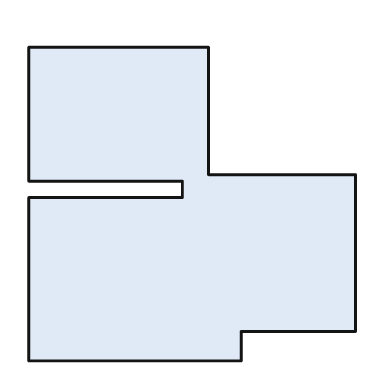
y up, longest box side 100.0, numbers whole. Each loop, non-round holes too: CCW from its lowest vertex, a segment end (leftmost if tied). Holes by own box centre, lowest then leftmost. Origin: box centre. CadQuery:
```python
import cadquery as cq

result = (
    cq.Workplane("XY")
    .moveTo(-50.0, -48.0)
    .lineTo(15.0, -48.0)
    .lineTo(15.0, -39.0)
    .lineTo(50.0, -39.0)
    .lineTo(50.0, 9.0)
    .lineTo(5.0, 9.0)
    .lineTo(5.0, 48.0)
    .lineTo(-50.0, 48.0)
    .lineTo(-50.0, 7.0)
    .lineTo(-3.0, 7.0)
    .lineTo(-3.0, 2.0)
    .lineTo(-50.0, 2.0)
    .close()
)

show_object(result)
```